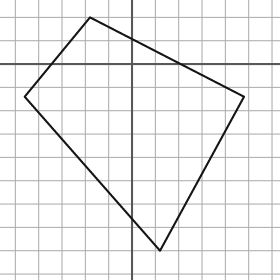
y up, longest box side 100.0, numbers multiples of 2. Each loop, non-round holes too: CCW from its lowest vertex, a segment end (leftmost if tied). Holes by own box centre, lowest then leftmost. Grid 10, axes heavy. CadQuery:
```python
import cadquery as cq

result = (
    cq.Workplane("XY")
    .moveTo(12.0, -80.0)
    .lineTo(48.0, -14.0)
    .lineTo(-18.0, 20.0)
    .lineTo(-46.0, -14.0)
    .close()
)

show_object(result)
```